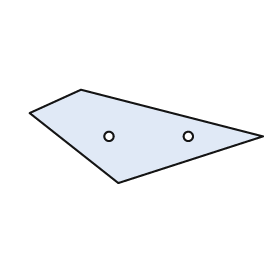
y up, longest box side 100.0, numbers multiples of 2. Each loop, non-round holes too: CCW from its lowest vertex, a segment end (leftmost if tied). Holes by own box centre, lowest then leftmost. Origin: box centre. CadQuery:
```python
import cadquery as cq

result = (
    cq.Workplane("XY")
    .moveTo(-12.0, -20.0)
    .lineTo(50.0, 0.0)
    .lineTo(-28.0, 20.0)
    .lineTo(-50.0, 10.0)
    .close()
    .moveTo(-16.0, 0.0)
    .circle(2.0)
    .moveTo(18.0, 0.0)
    .circle(2.0)
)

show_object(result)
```